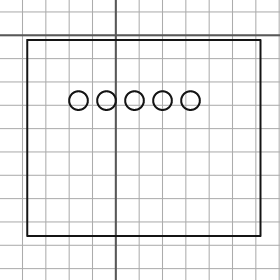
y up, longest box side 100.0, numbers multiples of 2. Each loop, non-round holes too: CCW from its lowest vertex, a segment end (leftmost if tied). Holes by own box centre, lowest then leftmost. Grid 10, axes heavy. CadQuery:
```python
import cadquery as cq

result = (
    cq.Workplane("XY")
    .moveTo(-38.0, -86.0)
    .lineTo(62.0, -86.0)
    .lineTo(62.0, -2.0)
    .lineTo(-38.0, -2.0)
    .close()
    .moveTo(-16.0, -28.0)
    .circle(4.0)
    .moveTo(-4.0, -28.0)
    .circle(4.0)
    .moveTo(8.0, -28.0)
    .circle(4.0)
    .moveTo(20.0, -28.0)
    .circle(4.0)
    .moveTo(32.0, -28.0)
    .circle(4.0)
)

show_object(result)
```